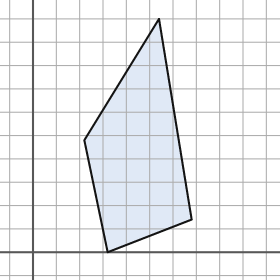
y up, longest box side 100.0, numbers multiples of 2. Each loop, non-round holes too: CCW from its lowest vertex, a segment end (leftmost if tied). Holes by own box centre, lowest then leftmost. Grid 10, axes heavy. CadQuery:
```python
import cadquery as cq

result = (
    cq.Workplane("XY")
    .moveTo(32.0, 0.0)
    .lineTo(68.0, 14.0)
    .lineTo(54.0, 100.0)
    .lineTo(22.0, 48.0)
    .close()
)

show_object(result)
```